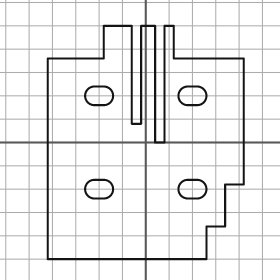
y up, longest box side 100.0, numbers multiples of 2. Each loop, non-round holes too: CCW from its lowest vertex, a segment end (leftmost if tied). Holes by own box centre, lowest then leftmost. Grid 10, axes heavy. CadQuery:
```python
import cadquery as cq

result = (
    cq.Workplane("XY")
    .moveTo(-42.0, -50.0)
    .lineTo(26.0, -50.0)
    .lineTo(26.0, -36.0)
    .lineTo(34.0, -36.0)
    .lineTo(34.0, -18.0)
    .lineTo(42.0, -18.0)
    .lineTo(42.0, 36.0)
    .lineTo(12.0, 36.0)
    .lineTo(12.0, 50.0)
    .lineTo(8.0, 50.0)
    .lineTo(8.0, 0.0)
    .lineTo(4.0, 0.0)
    .lineTo(4.0, 50.0)
    .lineTo(-2.0, 50.0)
    .lineTo(-2.0, 8.0)
    .lineTo(-6.0, 8.0)
    .lineTo(-6.0, 50.0)
    .lineTo(-18.0, 50.0)
    .lineTo(-18.0, 36.0)
    .lineTo(-42.0, 36.0)
    .close()
    .moveTo(-22.0, -24.0)
    .lineTo(-18.0, -24.0)
    .threePointArc((-14.0, -20.0), (-18.0, -16.0))
    .lineTo(-22.0, -16.0)
    .threePointArc((-26.0, -20.0), (-22.0, -24.0))
    .close()
    .moveTo(18.0, -24.0)
    .lineTo(22.0, -24.0)
    .threePointArc((26.0, -20.0), (22.0, -16.0))
    .lineTo(18.0, -16.0)
    .threePointArc((14.0, -20.0), (18.0, -24.0))
    .close()
    .moveTo(-22.0, 16.0)
    .lineTo(-18.0, 16.0)
    .threePointArc((-14.0, 20.0), (-18.0, 24.0))
    .lineTo(-22.0, 24.0)
    .threePointArc((-26.0, 20.0), (-22.0, 16.0))
    .close()
    .moveTo(18.0, 16.0)
    .lineTo(22.0, 16.0)
    .threePointArc((26.0, 20.0), (22.0, 24.0))
    .lineTo(18.0, 24.0)
    .threePointArc((14.0, 20.0), (18.0, 16.0))
    .close()
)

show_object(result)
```